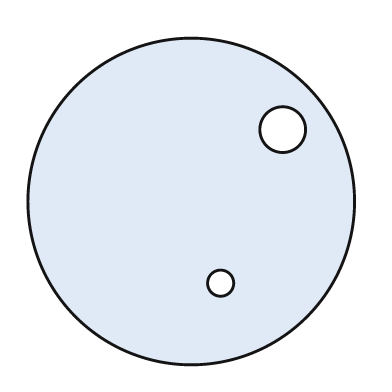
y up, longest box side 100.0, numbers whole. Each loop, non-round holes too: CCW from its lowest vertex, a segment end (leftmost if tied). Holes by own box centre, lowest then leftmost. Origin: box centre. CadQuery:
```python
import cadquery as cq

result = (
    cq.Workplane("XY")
    .moveTo(0.0, 0.0)
    .circle(50.0)
    .moveTo(9.0, -25.0)
    .circle(4.0)
    .moveTo(28.0, 22.0)
    .circle(7.0)
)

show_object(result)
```